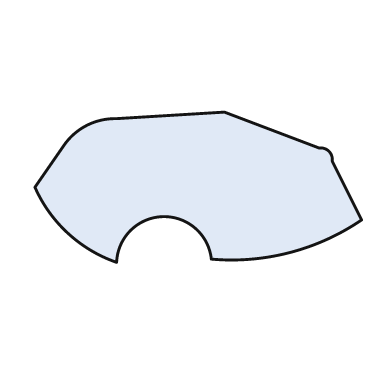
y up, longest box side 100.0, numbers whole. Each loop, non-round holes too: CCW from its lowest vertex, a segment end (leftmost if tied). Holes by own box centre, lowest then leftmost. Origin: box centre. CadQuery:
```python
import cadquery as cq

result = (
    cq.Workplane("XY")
    .moveTo(-25.0, -23.0)
    .threePointArc((-11.0, -9.0), (4.0, -22.0))
    .threePointArc((28.0, -20.0), (50.0, -10.0))
    .lineTo(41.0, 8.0)
    .threePointArc((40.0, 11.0), (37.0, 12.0))
    .lineTo(8.0, 23.0)
    .lineTo(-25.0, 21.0)
    .threePointArc((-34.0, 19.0), (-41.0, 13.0))
    .lineTo(-50.0, 0.0)
    .threePointArc((-40.0, -14.0), (-25.0, -23.0))
    .close()
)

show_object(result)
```